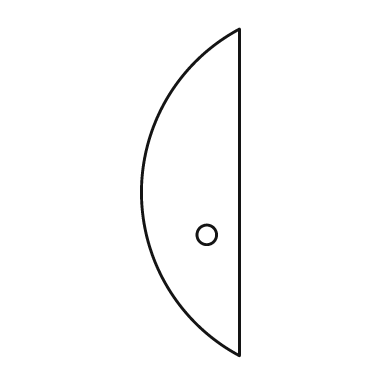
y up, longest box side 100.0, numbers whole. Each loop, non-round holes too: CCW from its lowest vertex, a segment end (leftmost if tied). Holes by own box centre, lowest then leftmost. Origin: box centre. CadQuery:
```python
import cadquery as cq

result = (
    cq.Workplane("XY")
    .moveTo(15.0, -50.0)
    .lineTo(15.0, 50.0)
    .threePointArc((-15.0, 0.0), (15.0, -50.0))
    .close()
    .moveTo(5.0, -13.0)
    .circle(3.0)
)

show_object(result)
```